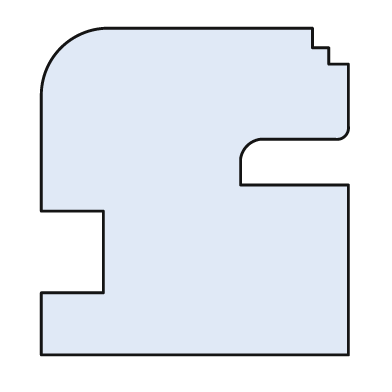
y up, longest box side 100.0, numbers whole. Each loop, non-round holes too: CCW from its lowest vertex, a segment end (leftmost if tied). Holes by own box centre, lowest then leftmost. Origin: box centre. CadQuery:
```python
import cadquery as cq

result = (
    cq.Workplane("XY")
    .moveTo(-47.0, -50.0)
    .lineTo(47.0, -50.0)
    .lineTo(47.0, 2.0)
    .lineTo(14.0, 2.0)
    .lineTo(14.0, 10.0)
    .threePointArc((16.0, 14.0), (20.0, 16.0))
    .lineTo(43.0, 16.0)
    .threePointArc((46.0, 17.0), (47.0, 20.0))
    .lineTo(47.0, 39.0)
    .lineTo(41.0, 39.0)
    .lineTo(41.0, 44.0)
    .lineTo(36.0, 44.0)
    .lineTo(36.0, 50.0)
    .lineTo(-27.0, 50.0)
    .threePointArc((-41.0, 44.0), (-47.0, 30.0))
    .lineTo(-47.0, -6.0)
    .lineTo(-28.0, -6.0)
    .lineTo(-28.0, -31.0)
    .lineTo(-47.0, -31.0)
    .close()
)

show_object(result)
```